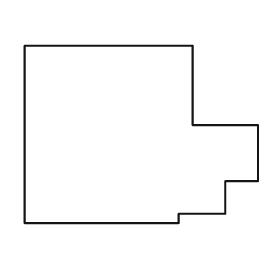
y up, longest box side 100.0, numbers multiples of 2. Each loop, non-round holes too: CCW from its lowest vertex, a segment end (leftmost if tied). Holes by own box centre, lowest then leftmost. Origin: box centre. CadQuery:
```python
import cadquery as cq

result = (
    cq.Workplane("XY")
    .moveTo(-50.0, -38.0)
    .lineTo(16.0, -38.0)
    .lineTo(16.0, -34.0)
    .lineTo(36.0, -34.0)
    .lineTo(36.0, -20.0)
    .lineTo(50.0, -20.0)
    .lineTo(50.0, 4.0)
    .lineTo(22.0, 4.0)
    .lineTo(22.0, 38.0)
    .lineTo(-50.0, 38.0)
    .close()
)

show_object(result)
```